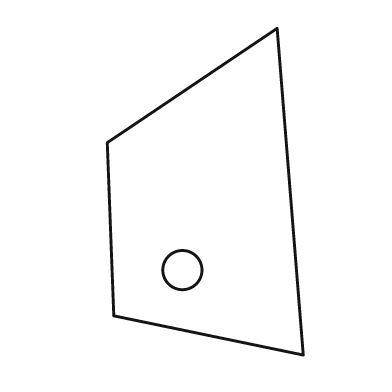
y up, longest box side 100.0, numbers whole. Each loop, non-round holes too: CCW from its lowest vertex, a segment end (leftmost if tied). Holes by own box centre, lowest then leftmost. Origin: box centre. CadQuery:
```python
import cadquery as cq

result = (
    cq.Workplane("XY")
    .moveTo(30.0, -50.0)
    .lineTo(22.0, 50.0)
    .lineTo(-30.0, 15.0)
    .lineTo(-28.0, -38.0)
    .close()
    .moveTo(-7.0, -24.0)
    .circle(6.0)
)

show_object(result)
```